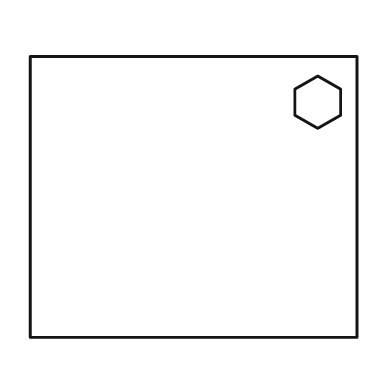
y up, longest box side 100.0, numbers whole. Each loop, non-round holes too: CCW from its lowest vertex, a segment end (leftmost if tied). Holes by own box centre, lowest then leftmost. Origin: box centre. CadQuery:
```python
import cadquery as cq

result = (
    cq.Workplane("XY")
    .moveTo(-50.0, -43.0)
    .lineTo(50.0, -43.0)
    .lineTo(50.0, 43.0)
    .lineTo(-50.0, 43.0)
    .close()
    .moveTo(38.0, 21.0)
    .lineTo(45.0, 25.0)
    .lineTo(45.0, 33.0)
    .lineTo(38.0, 37.0)
    .lineTo(31.0, 33.0)
    .lineTo(31.0, 25.0)
    .close()
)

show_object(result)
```